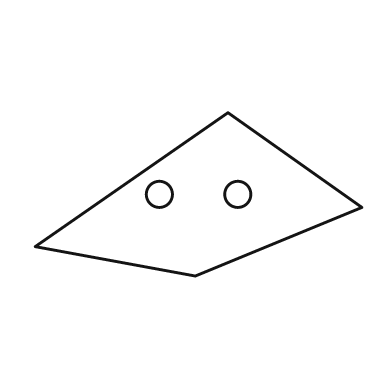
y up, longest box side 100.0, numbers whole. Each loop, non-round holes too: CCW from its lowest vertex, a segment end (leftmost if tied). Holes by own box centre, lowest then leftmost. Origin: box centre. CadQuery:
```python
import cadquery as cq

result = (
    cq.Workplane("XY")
    .moveTo(-1.0, -25.0)
    .lineTo(50.0, -4.0)
    .lineTo(9.0, 25.0)
    .lineTo(-50.0, -16.0)
    .close()
    .moveTo(-12.0, 0.0)
    .circle(4.0)
    .moveTo(12.0, 0.0)
    .circle(4.0)
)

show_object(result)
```